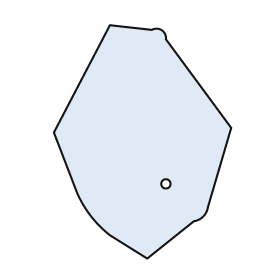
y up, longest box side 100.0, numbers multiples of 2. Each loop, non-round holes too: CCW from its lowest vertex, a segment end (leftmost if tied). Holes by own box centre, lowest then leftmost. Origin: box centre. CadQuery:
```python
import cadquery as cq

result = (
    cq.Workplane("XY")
    .moveTo(2.0, -50.0)
    .lineTo(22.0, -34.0)
    .threePointArc((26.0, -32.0), (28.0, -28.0))
    .lineTo(38.0, 6.0)
    .lineTo(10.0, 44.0)
    .threePointArc((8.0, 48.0), (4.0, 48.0))
    .lineTo(-14.0, 50.0)
    .lineTo(-38.0, 4.0)
    .lineTo(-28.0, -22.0)
    .threePointArc((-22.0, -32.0), (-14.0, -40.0))
    .close()
    .moveTo(10.0, -18.0)
    .circle(2.0)
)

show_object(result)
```